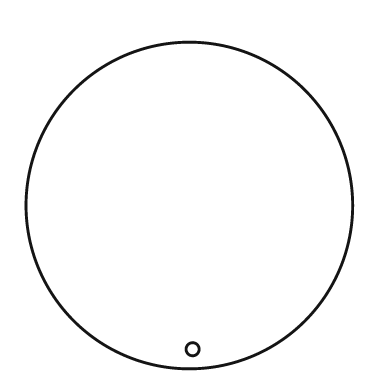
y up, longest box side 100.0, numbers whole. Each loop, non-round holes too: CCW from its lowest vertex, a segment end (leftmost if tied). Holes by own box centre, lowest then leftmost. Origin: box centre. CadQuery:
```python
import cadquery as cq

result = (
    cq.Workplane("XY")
    .moveTo(0.0, 0.0)
    .circle(50.0)
    .moveTo(1.0, -44.0)
    .circle(2.0)
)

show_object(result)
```